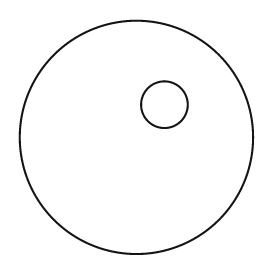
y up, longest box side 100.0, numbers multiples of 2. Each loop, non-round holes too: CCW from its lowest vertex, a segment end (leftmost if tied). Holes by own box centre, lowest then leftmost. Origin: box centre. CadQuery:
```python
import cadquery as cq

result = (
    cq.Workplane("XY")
    .moveTo(0.0, 0.0)
    .circle(50.0)
    .moveTo(12.0, 14.0)
    .circle(10.0)
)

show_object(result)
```